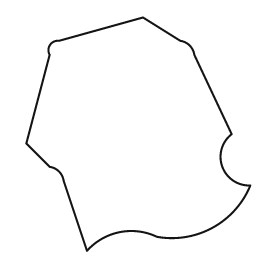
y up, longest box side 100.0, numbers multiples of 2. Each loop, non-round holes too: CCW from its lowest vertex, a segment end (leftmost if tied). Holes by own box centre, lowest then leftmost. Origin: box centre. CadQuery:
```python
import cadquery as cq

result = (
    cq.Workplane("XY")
    .moveTo(-22.0, -50.0)
    .threePointArc((-8.0, -42.0), (8.0, -44.0))
    .threePointArc((32.0, -40.0), (48.0, -22.0))
    .threePointArc((36.0, -14.0), (40.0, 0.0))
    .lineTo(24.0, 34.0)
    .threePointArc((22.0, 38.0), (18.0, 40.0))
    .lineTo(2.0, 50.0)
    .lineTo(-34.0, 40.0)
    .threePointArc((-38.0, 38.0), (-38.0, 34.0))
    .lineTo(-48.0, -4.0)
    .lineTo(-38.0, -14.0)
    .threePointArc((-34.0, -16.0), (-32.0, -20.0))
    .close()
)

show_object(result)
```